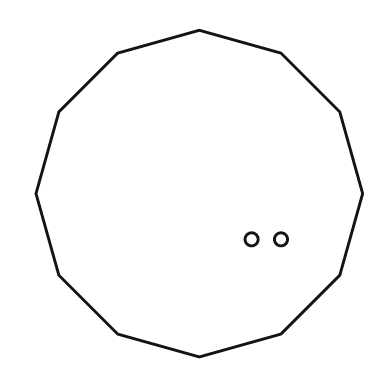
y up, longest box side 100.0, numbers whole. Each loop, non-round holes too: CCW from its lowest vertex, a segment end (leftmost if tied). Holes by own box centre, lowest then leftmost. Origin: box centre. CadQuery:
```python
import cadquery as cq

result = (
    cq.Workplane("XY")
    .moveTo(0.0, -50.0)
    .lineTo(25.0, -43.0)
    .lineTo(43.0, -25.0)
    .lineTo(50.0, 0.0)
    .lineTo(43.0, 25.0)
    .lineTo(25.0, 43.0)
    .lineTo(0.0, 50.0)
    .lineTo(-25.0, 43.0)
    .lineTo(-43.0, 25.0)
    .lineTo(-50.0, 0.0)
    .lineTo(-43.0, -25.0)
    .lineTo(-25.0, -43.0)
    .close()
    .moveTo(16.0, -14.0)
    .circle(2.0)
    .moveTo(25.0, -14.0)
    .circle(2.0)
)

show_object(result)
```